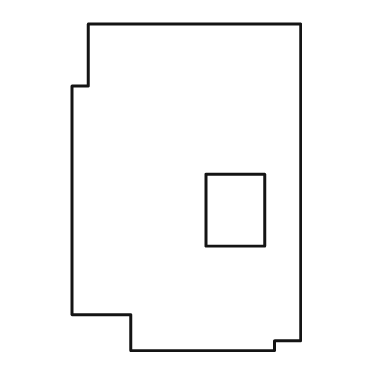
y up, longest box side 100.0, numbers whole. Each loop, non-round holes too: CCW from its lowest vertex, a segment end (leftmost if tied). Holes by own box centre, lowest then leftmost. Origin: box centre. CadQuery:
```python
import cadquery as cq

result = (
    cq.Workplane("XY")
    .moveTo(-17.0, -50.0)
    .lineTo(27.0, -50.0)
    .lineTo(27.0, -47.0)
    .lineTo(35.0, -47.0)
    .lineTo(35.0, 50.0)
    .lineTo(-30.0, 50.0)
    .lineTo(-30.0, 31.0)
    .lineTo(-35.0, 31.0)
    .lineTo(-35.0, -39.0)
    .lineTo(-17.0, -39.0)
    .close()
    .moveTo(6.0, -18.0)
    .lineTo(24.0, -18.0)
    .lineTo(24.0, 4.0)
    .lineTo(6.0, 4.0)
    .close()
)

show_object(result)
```